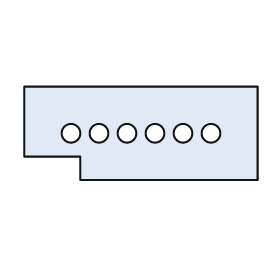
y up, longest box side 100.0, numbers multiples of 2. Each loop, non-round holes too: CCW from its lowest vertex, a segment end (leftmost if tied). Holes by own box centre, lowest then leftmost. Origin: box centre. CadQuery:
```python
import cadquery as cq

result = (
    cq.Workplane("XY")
    .moveTo(-26.0, -20.0)
    .lineTo(50.0, -20.0)
    .lineTo(50.0, 20.0)
    .lineTo(-50.0, 20.0)
    .lineTo(-50.0, -10.0)
    .lineTo(-26.0, -10.0)
    .close()
    .moveTo(-30.0, 0.0)
    .circle(4.0)
    .moveTo(-18.0, 0.0)
    .circle(4.0)
    .moveTo(-6.0, 0.0)
    .circle(4.0)
    .moveTo(6.0, 0.0)
    .circle(4.0)
    .moveTo(18.0, 0.0)
    .circle(4.0)
    .moveTo(30.0, 0.0)
    .circle(4.0)
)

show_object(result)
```